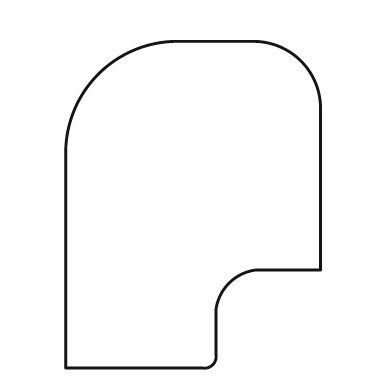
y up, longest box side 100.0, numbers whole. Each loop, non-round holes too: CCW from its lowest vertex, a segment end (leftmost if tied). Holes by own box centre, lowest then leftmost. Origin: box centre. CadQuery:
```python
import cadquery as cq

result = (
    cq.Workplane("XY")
    .moveTo(-39.0, -50.0)
    .lineTo(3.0, -50.0)
    .threePointArc((6.0, -49.0), (7.0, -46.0))
    .lineTo(7.0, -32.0)
    .threePointArc((11.0, -24.0), (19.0, -20.0))
    .lineTo(39.0, -20.0)
    .lineTo(39.0, 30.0)
    .threePointArc((33.0, 44.0), (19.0, 50.0))
    .lineTo(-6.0, 50.0)
    .threePointArc((-29.0, 40.0), (-39.0, 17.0))
    .close()
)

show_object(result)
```